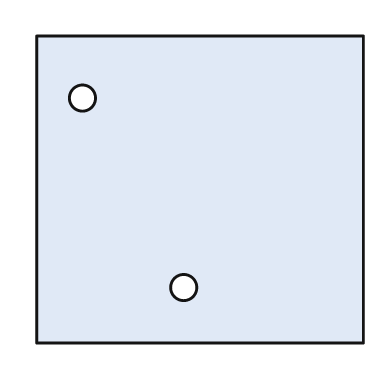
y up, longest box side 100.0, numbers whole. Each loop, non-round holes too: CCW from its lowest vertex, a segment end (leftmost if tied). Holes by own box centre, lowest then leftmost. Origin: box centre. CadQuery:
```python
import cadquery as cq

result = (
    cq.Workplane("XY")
    .moveTo(-50.0, -47.0)
    .lineTo(50.0, -47.0)
    .lineTo(50.0, 47.0)
    .lineTo(-50.0, 47.0)
    .close()
    .moveTo(-5.0, -30.0)
    .circle(4.0)
    .moveTo(-36.0, 28.0)
    .circle(4.0)
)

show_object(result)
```